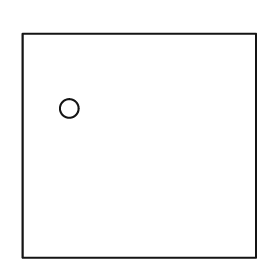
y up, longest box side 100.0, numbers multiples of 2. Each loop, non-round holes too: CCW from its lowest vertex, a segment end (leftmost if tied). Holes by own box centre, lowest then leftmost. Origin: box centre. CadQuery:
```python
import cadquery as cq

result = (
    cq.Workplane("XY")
    .moveTo(-50.0, -48.0)
    .lineTo(50.0, -48.0)
    .lineTo(50.0, 48.0)
    .lineTo(-50.0, 48.0)
    .close()
    .moveTo(-30.0, 16.0)
    .circle(4.0)
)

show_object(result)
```